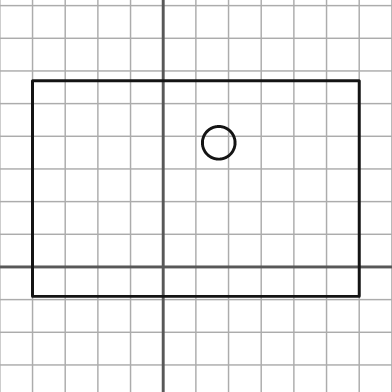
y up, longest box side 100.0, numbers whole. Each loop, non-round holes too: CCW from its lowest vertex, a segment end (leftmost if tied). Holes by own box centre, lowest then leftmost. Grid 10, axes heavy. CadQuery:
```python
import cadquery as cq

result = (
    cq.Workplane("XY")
    .moveTo(-40.0, -9.0)
    .lineTo(60.0, -9.0)
    .lineTo(60.0, 57.0)
    .lineTo(-40.0, 57.0)
    .close()
    .moveTo(17.0, 38.0)
    .circle(5.0)
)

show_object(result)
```